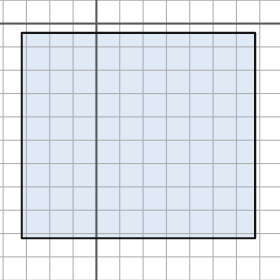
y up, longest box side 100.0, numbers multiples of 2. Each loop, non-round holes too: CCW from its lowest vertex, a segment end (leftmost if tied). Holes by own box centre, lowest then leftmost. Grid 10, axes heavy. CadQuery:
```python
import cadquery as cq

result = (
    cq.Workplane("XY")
    .moveTo(-32.0, -92.0)
    .lineTo(68.0, -92.0)
    .lineTo(68.0, -4.0)
    .lineTo(-32.0, -4.0)
    .close()
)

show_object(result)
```